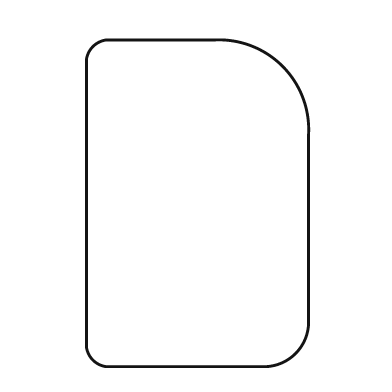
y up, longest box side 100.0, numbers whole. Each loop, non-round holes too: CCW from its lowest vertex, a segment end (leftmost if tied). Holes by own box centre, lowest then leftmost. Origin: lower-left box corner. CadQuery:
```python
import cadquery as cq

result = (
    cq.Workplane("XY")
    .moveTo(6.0, 0.0)
    .lineTo(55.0, 0.0)
    .threePointArc((64.0, 4.0), (68.0, 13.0))
    .lineTo(68.0, 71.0)
    .threePointArc((60.0, 92.0), (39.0, 100.0))
    .lineTo(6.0, 100.0)
    .threePointArc((2.0, 98.0), (0.0, 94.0))
    .lineTo(0.0, 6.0)
    .threePointArc((2.0, 2.0), (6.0, 0.0))
    .close()
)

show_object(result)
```